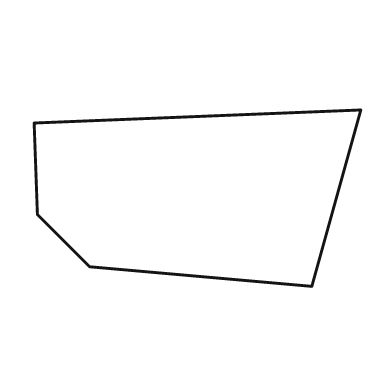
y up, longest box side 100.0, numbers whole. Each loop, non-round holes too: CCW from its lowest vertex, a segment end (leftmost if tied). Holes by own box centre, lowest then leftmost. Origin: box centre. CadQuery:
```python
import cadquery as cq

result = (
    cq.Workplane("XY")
    .moveTo(35.0, -27.0)
    .lineTo(50.0, 27.0)
    .lineTo(-50.0, 23.0)
    .lineTo(-49.0, -5.0)
    .lineTo(-33.0, -21.0)
    .close()
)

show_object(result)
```